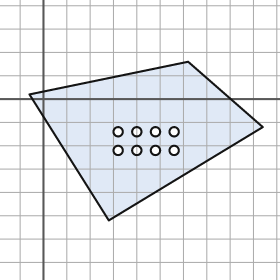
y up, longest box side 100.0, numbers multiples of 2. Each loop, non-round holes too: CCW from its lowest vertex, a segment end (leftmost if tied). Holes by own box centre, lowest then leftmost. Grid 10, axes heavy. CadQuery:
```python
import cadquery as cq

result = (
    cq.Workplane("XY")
    .moveTo(28.0, -52.0)
    .lineTo(94.0, -12.0)
    .lineTo(62.0, 16.0)
    .lineTo(-6.0, 2.0)
    .close()
    .moveTo(32.0, -22.0)
    .circle(2.0)
    .moveTo(40.0, -22.0)
    .circle(2.0)
    .moveTo(48.0, -22.0)
    .circle(2.0)
    .moveTo(56.0, -22.0)
    .circle(2.0)
    .moveTo(32.0, -14.0)
    .circle(2.0)
    .moveTo(40.0, -14.0)
    .circle(2.0)
    .moveTo(48.0, -14.0)
    .circle(2.0)
    .moveTo(56.0, -14.0)
    .circle(2.0)
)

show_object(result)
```